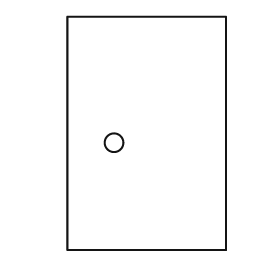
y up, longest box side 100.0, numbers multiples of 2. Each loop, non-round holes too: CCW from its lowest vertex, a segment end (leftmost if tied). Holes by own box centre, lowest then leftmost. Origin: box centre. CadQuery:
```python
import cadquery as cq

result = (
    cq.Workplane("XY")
    .moveTo(-34.0, -50.0)
    .lineTo(34.0, -50.0)
    .lineTo(34.0, 50.0)
    .lineTo(-34.0, 50.0)
    .close()
    .moveTo(-14.0, -4.0)
    .circle(4.0)
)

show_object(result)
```